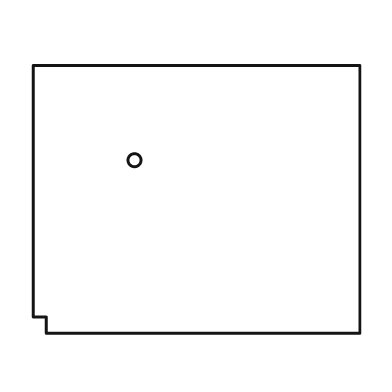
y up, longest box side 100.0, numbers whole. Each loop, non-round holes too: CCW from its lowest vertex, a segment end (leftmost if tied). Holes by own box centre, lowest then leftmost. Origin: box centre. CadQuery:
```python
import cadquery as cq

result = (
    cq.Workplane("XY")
    .moveTo(-46.0, -41.0)
    .lineTo(50.0, -41.0)
    .lineTo(50.0, 41.0)
    .lineTo(-50.0, 41.0)
    .lineTo(-50.0, -36.0)
    .lineTo(-46.0, -36.0)
    .close()
    .moveTo(-19.0, 12.0)
    .circle(2.0)
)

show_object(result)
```